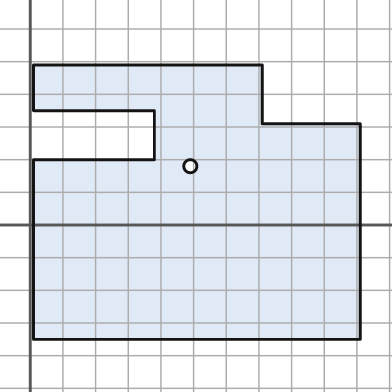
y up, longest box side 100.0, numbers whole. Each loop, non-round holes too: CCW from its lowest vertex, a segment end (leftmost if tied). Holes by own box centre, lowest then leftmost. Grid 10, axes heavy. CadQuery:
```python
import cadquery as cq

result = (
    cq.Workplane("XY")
    .moveTo(1.0, -35.0)
    .lineTo(101.0, -35.0)
    .lineTo(101.0, 31.0)
    .lineTo(71.0, 31.0)
    .lineTo(71.0, 49.0)
    .lineTo(1.0, 49.0)
    .lineTo(1.0, 35.0)
    .lineTo(38.0, 35.0)
    .lineTo(38.0, 20.0)
    .lineTo(1.0, 20.0)
    .close()
    .moveTo(49.0, 18.0)
    .circle(2.0)
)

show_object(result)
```